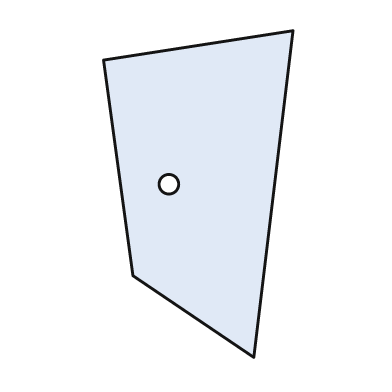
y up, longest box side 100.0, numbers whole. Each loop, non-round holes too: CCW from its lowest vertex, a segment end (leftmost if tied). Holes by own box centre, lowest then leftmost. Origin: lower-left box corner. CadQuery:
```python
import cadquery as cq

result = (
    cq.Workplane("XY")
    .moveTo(46.0, 0.0)
    .lineTo(58.0, 100.0)
    .lineTo(0.0, 91.0)
    .lineTo(9.0, 25.0)
    .close()
    .moveTo(20.0, 53.0)
    .circle(3.0)
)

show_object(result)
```